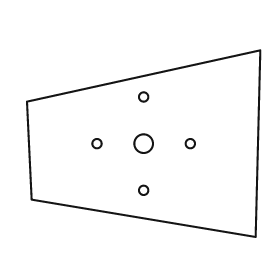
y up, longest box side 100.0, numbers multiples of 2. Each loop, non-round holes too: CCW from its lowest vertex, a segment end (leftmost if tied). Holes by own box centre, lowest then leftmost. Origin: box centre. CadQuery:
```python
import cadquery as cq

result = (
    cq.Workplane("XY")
    .moveTo(48.0, -40.0)
    .lineTo(50.0, 40.0)
    .lineTo(-50.0, 18.0)
    .lineTo(-48.0, -24.0)
    .close()
    .moveTo(0.0, -20.0)
    .circle(2.0)
    .moveTo(-20.0, 0.0)
    .circle(2.0)
    .moveTo(0.0, 0.0)
    .circle(4.0)
    .moveTo(20.0, 0.0)
    .circle(2.0)
    .moveTo(0.0, 20.0)
    .circle(2.0)
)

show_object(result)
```